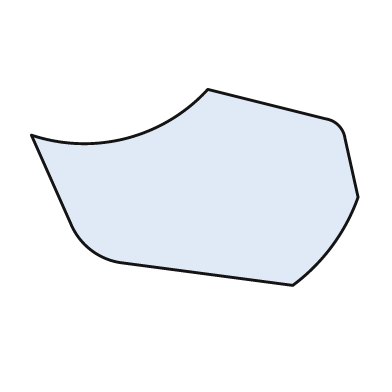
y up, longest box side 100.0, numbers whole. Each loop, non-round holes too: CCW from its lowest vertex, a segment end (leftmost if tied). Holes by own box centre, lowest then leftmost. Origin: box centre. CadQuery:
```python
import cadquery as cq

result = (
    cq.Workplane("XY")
    .moveTo(30.0, -30.0)
    .threePointArc((42.0, -18.0), (50.0, -3.0))
    .lineTo(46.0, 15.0)
    .threePointArc((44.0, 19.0), (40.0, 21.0))
    .lineTo(4.0, 30.0)
    .threePointArc((-21.0, 15.0), (-50.0, 16.0))
    .lineTo(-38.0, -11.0)
    .threePointArc((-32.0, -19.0), (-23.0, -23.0))
    .close()
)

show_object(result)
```